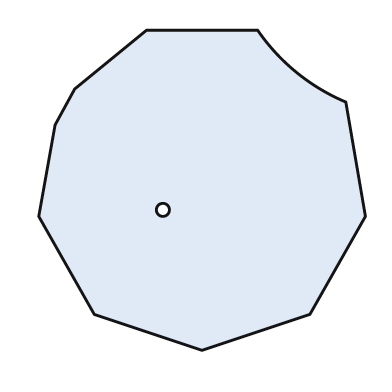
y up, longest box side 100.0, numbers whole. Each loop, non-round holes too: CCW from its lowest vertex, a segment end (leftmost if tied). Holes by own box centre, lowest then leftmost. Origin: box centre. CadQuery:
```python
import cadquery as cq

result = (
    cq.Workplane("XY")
    .moveTo(0.0, -49.0)
    .lineTo(33.0, -38.0)
    .lineTo(50.0, -8.0)
    .lineTo(44.0, 27.0)
    .threePointArc((29.0, 36.0), (17.0, 49.0))
    .lineTo(-17.0, 49.0)
    .lineTo(-39.0, 31.0)
    .lineTo(-45.0, 20.0)
    .lineTo(-50.0, -8.0)
    .lineTo(-33.0, -38.0)
    .close()
    .moveTo(-12.0, -6.0)
    .circle(2.0)
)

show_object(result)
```